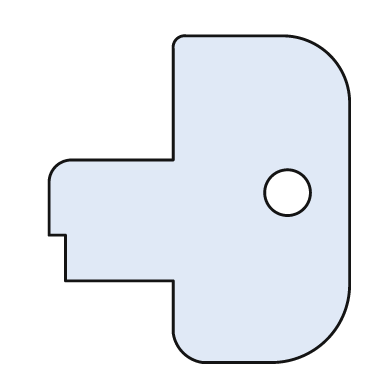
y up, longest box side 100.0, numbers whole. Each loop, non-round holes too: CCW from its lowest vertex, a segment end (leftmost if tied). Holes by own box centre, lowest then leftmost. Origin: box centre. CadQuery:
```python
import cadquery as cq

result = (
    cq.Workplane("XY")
    .moveTo(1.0, -50.0)
    .lineTo(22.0, -50.0)
    .threePointArc((39.0, -43.0), (46.0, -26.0))
    .lineTo(46.0, 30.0)
    .threePointArc((40.0, 44.0), (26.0, 50.0))
    .lineTo(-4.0, 50.0)
    .threePointArc((-7.0, 49.0), (-8.0, 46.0))
    .lineTo(-8.0, 12.0)
    .lineTo(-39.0, 12.0)
    .threePointArc((-44.0, 10.0), (-46.0, 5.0))
    .lineTo(-46.0, -11.0)
    .lineTo(-41.0, -11.0)
    .lineTo(-41.0, -25.0)
    .lineTo(-8.0, -25.0)
    .lineTo(-8.0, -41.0)
    .threePointArc((-5.0, -47.0), (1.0, -50.0))
    .close()
    .moveTo(27.0, 2.0)
    .circle(7.0)
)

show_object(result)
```